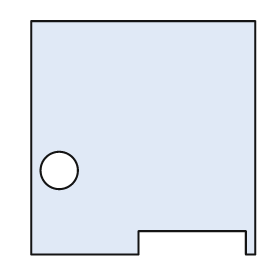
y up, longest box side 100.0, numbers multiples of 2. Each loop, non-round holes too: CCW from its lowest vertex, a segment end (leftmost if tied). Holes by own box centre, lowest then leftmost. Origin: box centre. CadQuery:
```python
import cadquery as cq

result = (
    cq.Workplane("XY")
    .moveTo(-48.0, -50.0)
    .lineTo(-2.0, -50.0)
    .lineTo(-2.0, -40.0)
    .lineTo(44.0, -40.0)
    .lineTo(44.0, -50.0)
    .lineTo(48.0, -50.0)
    .lineTo(48.0, 50.0)
    .lineTo(-48.0, 50.0)
    .close()
    .moveTo(-36.0, -14.0)
    .circle(8.0)
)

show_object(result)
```